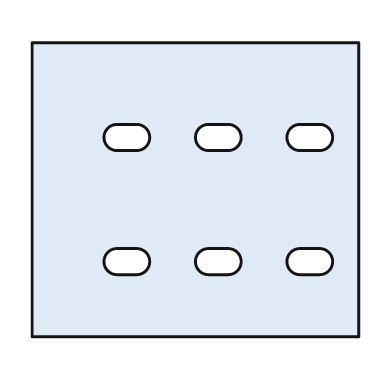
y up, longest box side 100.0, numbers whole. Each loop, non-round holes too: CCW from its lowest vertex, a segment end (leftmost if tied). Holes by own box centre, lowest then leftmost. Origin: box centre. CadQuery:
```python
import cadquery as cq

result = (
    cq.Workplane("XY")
    .moveTo(-50.0, -45.0)
    .lineTo(50.0, -45.0)
    .lineTo(50.0, 45.0)
    .lineTo(-50.0, 45.0)
    .close()
    .moveTo(-24.0, -26.0)
    .lineTo(-18.0, -26.0)
    .threePointArc((-14.0, -22.0), (-18.0, -18.0))
    .lineTo(-24.0, -18.0)
    .threePointArc((-28.0, -22.0), (-24.0, -26.0))
    .close()
    .moveTo(4.0, -26.0)
    .lineTo(10.0, -26.0)
    .threePointArc((14.0, -22.0), (10.0, -18.0))
    .lineTo(4.0, -18.0)
    .threePointArc((0.0, -22.0), (4.0, -26.0))
    .close()
    .moveTo(32.0, -26.0)
    .lineTo(38.0, -26.0)
    .threePointArc((42.0, -22.0), (38.0, -18.0))
    .lineTo(32.0, -18.0)
    .threePointArc((28.0, -22.0), (32.0, -26.0))
    .close()
    .moveTo(-24.0, 12.0)
    .lineTo(-18.0, 12.0)
    .threePointArc((-14.0, 16.0), (-18.0, 20.0))
    .lineTo(-24.0, 20.0)
    .threePointArc((-28.0, 16.0), (-24.0, 12.0))
    .close()
    .moveTo(4.0, 12.0)
    .lineTo(10.0, 12.0)
    .threePointArc((14.0, 16.0), (10.0, 20.0))
    .lineTo(4.0, 20.0)
    .threePointArc((0.0, 16.0), (4.0, 12.0))
    .close()
    .moveTo(32.0, 12.0)
    .lineTo(38.0, 12.0)
    .threePointArc((42.0, 16.0), (38.0, 20.0))
    .lineTo(32.0, 20.0)
    .threePointArc((28.0, 16.0), (32.0, 12.0))
    .close()
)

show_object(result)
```